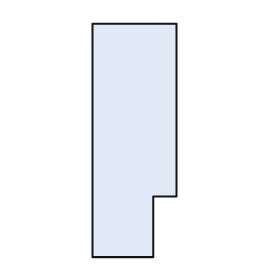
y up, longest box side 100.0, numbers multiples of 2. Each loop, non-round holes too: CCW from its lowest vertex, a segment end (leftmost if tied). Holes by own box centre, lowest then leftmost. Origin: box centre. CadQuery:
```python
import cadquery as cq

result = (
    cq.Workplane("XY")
    .moveTo(-18.0, -50.0)
    .lineTo(8.0, -50.0)
    .lineTo(8.0, -24.0)
    .lineTo(18.0, -24.0)
    .lineTo(18.0, 50.0)
    .lineTo(-18.0, 50.0)
    .close()
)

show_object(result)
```